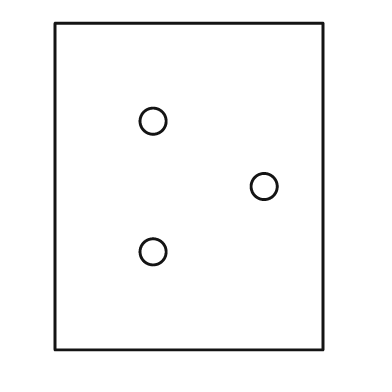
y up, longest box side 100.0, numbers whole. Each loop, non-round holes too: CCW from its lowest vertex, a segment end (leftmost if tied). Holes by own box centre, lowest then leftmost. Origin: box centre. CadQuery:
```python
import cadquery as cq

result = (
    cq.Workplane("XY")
    .moveTo(-41.0, -50.0)
    .lineTo(41.0, -50.0)
    .lineTo(41.0, 50.0)
    .lineTo(-41.0, 50.0)
    .close()
    .moveTo(-11.0, -20.0)
    .circle(4.0)
    .moveTo(23.0, 0.0)
    .circle(4.0)
    .moveTo(-11.0, 20.0)
    .circle(4.0)
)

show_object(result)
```